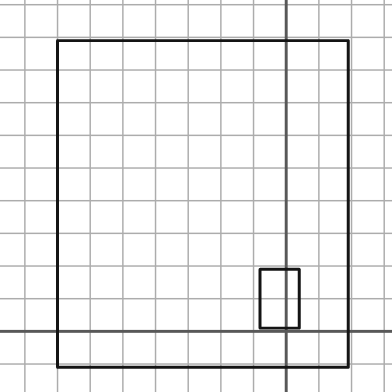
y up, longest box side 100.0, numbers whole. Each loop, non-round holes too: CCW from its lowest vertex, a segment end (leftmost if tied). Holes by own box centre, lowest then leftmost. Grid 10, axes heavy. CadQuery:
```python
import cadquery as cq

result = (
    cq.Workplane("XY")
    .moveTo(-70.0, -11.0)
    .lineTo(19.0, -11.0)
    .lineTo(19.0, 89.0)
    .lineTo(-70.0, 89.0)
    .close()
    .moveTo(-8.0, 1.0)
    .lineTo(4.0, 1.0)
    .lineTo(4.0, 19.0)
    .lineTo(-8.0, 19.0)
    .close()
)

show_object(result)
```